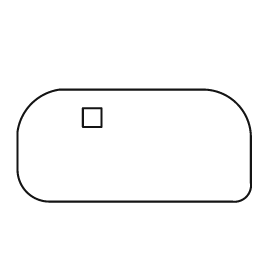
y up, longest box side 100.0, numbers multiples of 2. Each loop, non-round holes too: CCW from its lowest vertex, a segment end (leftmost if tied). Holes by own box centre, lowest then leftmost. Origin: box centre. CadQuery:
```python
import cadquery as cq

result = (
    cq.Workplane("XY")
    .moveTo(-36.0, -24.0)
    .lineTo(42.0, -24.0)
    .threePointArc((48.0, -22.0), (50.0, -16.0))
    .lineTo(50.0, 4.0)
    .threePointArc((44.0, 18.0), (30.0, 24.0))
    .lineTo(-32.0, 24.0)
    .threePointArc((-44.0, 18.0), (-50.0, 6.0))
    .lineTo(-50.0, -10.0)
    .threePointArc((-46.0, -20.0), (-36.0, -24.0))
    .close()
    .moveTo(-22.0, 8.0)
    .lineTo(-14.0, 8.0)
    .lineTo(-14.0, 16.0)
    .lineTo(-22.0, 16.0)
    .close()
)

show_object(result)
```